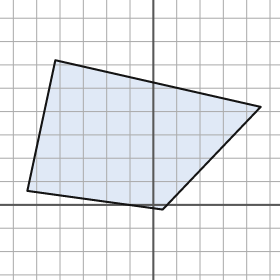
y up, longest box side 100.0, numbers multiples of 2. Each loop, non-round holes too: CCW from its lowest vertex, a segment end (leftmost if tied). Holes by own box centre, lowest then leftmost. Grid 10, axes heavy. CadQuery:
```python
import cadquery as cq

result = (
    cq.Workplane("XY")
    .moveTo(4.0, -2.0)
    .lineTo(46.0, 42.0)
    .lineTo(-42.0, 62.0)
    .lineTo(-54.0, 6.0)
    .close()
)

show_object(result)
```